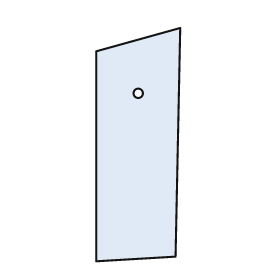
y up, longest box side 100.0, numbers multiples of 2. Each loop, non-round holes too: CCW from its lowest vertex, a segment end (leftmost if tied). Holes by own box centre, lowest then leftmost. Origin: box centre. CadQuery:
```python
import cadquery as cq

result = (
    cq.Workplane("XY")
    .moveTo(-18.0, -50.0)
    .lineTo(16.0, -48.0)
    .lineTo(18.0, 50.0)
    .lineTo(-18.0, 40.0)
    .close()
    .moveTo(0.0, 22.0)
    .circle(2.0)
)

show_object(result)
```